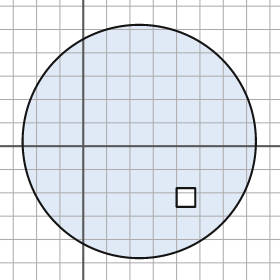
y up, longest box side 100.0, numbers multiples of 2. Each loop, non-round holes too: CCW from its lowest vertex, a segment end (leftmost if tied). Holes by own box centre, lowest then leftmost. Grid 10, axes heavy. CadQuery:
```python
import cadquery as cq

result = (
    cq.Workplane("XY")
    .moveTo(24.0, 2.0)
    .circle(50.0)
    .moveTo(40.0, -26.0)
    .lineTo(48.0, -26.0)
    .lineTo(48.0, -18.0)
    .lineTo(40.0, -18.0)
    .close()
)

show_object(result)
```